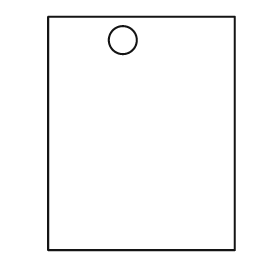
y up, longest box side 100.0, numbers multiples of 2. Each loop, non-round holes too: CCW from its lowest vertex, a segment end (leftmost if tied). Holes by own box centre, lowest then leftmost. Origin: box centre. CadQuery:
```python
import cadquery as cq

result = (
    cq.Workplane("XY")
    .moveTo(-40.0, -50.0)
    .lineTo(40.0, -50.0)
    .lineTo(40.0, 50.0)
    .lineTo(-40.0, 50.0)
    .close()
    .moveTo(-8.0, 40.0)
    .circle(6.0)
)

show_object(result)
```